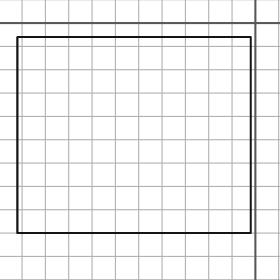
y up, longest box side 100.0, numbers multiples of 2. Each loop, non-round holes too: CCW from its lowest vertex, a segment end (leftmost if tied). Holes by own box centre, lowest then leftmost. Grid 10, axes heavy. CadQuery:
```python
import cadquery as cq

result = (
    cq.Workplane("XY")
    .moveTo(-102.0, -90.0)
    .lineTo(-2.0, -90.0)
    .lineTo(-2.0, -6.0)
    .lineTo(-102.0, -6.0)
    .close()
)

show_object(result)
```